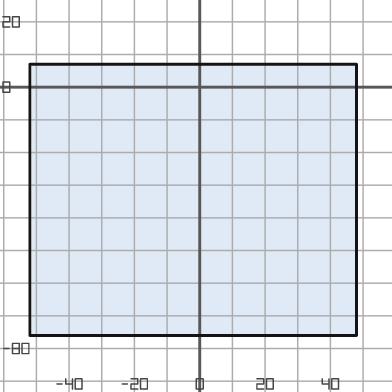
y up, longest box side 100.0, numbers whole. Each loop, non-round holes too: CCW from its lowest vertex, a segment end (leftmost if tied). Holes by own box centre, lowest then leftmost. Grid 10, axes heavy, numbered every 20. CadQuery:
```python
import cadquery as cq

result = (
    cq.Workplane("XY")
    .moveTo(-52.0, -76.0)
    .lineTo(48.0, -76.0)
    .lineTo(48.0, 7.0)
    .lineTo(-52.0, 7.0)
    .close()
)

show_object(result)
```